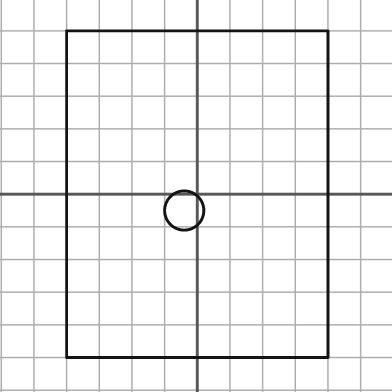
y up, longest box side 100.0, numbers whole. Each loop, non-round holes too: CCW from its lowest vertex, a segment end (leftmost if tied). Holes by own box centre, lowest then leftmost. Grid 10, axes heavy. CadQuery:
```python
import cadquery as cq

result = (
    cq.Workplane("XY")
    .moveTo(-40.0, -50.0)
    .lineTo(40.0, -50.0)
    .lineTo(40.0, 50.0)
    .lineTo(-40.0, 50.0)
    .close()
    .moveTo(-4.0, -5.0)
    .circle(6.0)
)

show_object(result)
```